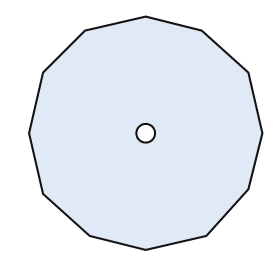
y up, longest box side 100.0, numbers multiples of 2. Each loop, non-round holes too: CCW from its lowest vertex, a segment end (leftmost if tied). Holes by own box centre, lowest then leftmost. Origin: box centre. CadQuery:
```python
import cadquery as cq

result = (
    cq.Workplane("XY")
    .moveTo(0.0, -50.0)
    .lineTo(26.0, -44.0)
    .lineTo(44.0, -24.0)
    .lineTo(50.0, 0.0)
    .lineTo(44.0, 26.0)
    .lineTo(24.0, 44.0)
    .lineTo(0.0, 50.0)
    .lineTo(-26.0, 44.0)
    .lineTo(-44.0, 26.0)
    .lineTo(-50.0, 0.0)
    .lineTo(-44.0, -26.0)
    .lineTo(-24.0, -44.0)
    .close()
    .moveTo(0.0, 0.0)
    .circle(4.0)
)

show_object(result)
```